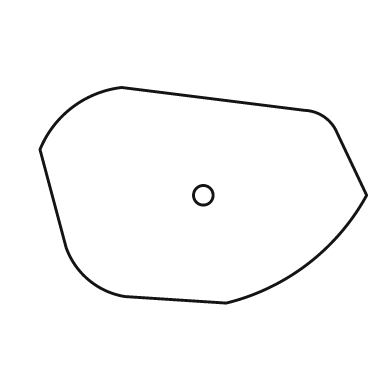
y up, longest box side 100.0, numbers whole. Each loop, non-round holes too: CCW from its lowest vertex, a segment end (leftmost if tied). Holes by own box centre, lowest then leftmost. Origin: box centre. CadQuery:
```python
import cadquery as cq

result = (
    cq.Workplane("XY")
    .moveTo(7.0, -33.0)
    .threePointArc((32.0, -21.0), (50.0, 0.0))
    .lineTo(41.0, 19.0)
    .threePointArc((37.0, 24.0), (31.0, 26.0))
    .lineTo(-25.0, 33.0)
    .threePointArc((-40.0, 27.0), (-50.0, 14.0))
    .lineTo(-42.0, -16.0)
    .threePointArc((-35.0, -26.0), (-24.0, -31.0))
    .close()
    .moveTo(0.0, 0.0)
    .circle(3.0)
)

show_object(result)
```